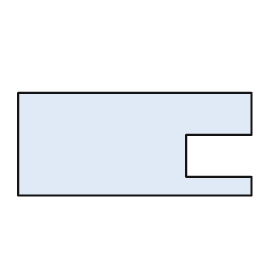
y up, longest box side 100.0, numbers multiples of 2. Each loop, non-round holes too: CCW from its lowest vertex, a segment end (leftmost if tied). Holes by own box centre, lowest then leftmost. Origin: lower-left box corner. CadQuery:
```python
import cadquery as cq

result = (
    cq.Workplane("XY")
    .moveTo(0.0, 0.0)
    .lineTo(100.0, 0.0)
    .lineTo(100.0, 8.0)
    .lineTo(72.0, 8.0)
    .lineTo(72.0, 26.0)
    .lineTo(100.0, 26.0)
    .lineTo(100.0, 44.0)
    .lineTo(0.0, 44.0)
    .close()
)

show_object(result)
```